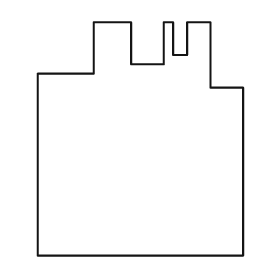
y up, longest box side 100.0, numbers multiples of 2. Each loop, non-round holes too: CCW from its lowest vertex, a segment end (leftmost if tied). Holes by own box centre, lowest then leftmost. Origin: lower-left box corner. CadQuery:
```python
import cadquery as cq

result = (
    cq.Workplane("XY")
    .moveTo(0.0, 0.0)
    .lineTo(88.0, 0.0)
    .lineTo(88.0, 72.0)
    .lineTo(74.0, 72.0)
    .lineTo(74.0, 100.0)
    .lineTo(64.0, 100.0)
    .lineTo(64.0, 86.0)
    .lineTo(58.0, 86.0)
    .lineTo(58.0, 100.0)
    .lineTo(54.0, 100.0)
    .lineTo(54.0, 82.0)
    .lineTo(40.0, 82.0)
    .lineTo(40.0, 100.0)
    .lineTo(24.0, 100.0)
    .lineTo(24.0, 78.0)
    .lineTo(0.0, 78.0)
    .close()
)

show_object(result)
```